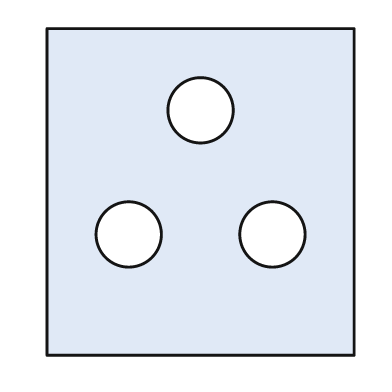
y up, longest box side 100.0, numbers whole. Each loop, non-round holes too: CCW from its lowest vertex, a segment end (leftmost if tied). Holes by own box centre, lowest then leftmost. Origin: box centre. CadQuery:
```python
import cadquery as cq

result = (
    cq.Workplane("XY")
    .moveTo(-47.0, -50.0)
    .lineTo(47.0, -50.0)
    .lineTo(47.0, 50.0)
    .lineTo(-47.0, 50.0)
    .close()
    .moveTo(-22.0, -13.0)
    .circle(10.0)
    .moveTo(22.0, -13.0)
    .circle(10.0)
    .moveTo(0.0, 25.0)
    .circle(10.0)
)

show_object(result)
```